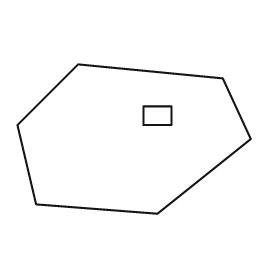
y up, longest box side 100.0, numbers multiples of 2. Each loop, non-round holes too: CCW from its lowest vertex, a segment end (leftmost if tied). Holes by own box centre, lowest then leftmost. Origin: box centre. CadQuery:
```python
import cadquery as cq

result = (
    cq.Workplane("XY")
    .moveTo(10.0, -32.0)
    .lineTo(50.0, 0.0)
    .lineTo(38.0, 26.0)
    .lineTo(-24.0, 32.0)
    .lineTo(-50.0, 6.0)
    .lineTo(-42.0, -28.0)
    .close()
    .moveTo(4.0, 6.0)
    .lineTo(16.0, 6.0)
    .lineTo(16.0, 14.0)
    .lineTo(4.0, 14.0)
    .close()
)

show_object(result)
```